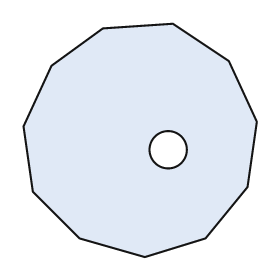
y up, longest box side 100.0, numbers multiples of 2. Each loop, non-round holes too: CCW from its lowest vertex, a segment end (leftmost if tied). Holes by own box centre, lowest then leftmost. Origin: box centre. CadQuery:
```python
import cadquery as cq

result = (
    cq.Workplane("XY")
    .moveTo(2.0, -50.0)
    .lineTo(28.0, -42.0)
    .lineTo(46.0, -20.0)
    .lineTo(50.0, 8.0)
    .lineTo(38.0, 34.0)
    .lineTo(14.0, 50.0)
    .lineTo(-16.0, 48.0)
    .lineTo(-38.0, 32.0)
    .lineTo(-50.0, 6.0)
    .lineTo(-46.0, -22.0)
    .lineTo(-26.0, -42.0)
    .close()
    .moveTo(12.0, -4.0)
    .circle(8.0)
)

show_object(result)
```